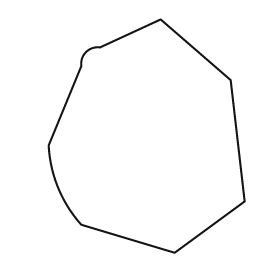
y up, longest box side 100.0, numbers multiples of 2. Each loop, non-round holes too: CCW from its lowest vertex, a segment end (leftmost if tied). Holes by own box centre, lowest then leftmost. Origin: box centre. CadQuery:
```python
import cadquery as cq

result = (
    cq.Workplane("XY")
    .moveTo(12.0, -50.0)
    .lineTo(42.0, -28.0)
    .lineTo(36.0, 24.0)
    .lineTo(6.0, 50.0)
    .lineTo(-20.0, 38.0)
    .threePointArc((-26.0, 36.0), (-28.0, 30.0))
    .lineTo(-42.0, -4.0)
    .threePointArc((-38.0, -22.0), (-28.0, -38.0))
    .close()
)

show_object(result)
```